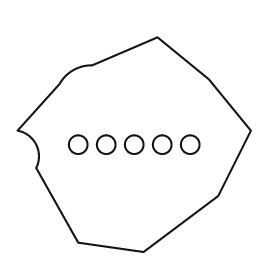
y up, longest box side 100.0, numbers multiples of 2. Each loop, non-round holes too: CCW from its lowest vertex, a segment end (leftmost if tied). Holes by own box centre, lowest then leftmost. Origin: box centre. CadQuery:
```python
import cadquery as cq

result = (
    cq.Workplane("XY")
    .moveTo(4.0, -46.0)
    .lineTo(36.0, -22.0)
    .lineTo(50.0, 6.0)
    .lineTo(32.0, 28.0)
    .lineTo(10.0, 46.0)
    .lineTo(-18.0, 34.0)
    .threePointArc((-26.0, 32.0), (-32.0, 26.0))
    .lineTo(-50.0, 6.0)
    .threePointArc((-42.0, 0.0), (-42.0, -10.0))
    .lineTo(-24.0, -42.0)
    .close()
    .moveTo(-24.0, 0.0)
    .circle(4.0)
    .moveTo(-12.0, 0.0)
    .circle(4.0)
    .moveTo(0.0, 0.0)
    .circle(4.0)
    .moveTo(12.0, 0.0)
    .circle(4.0)
    .moveTo(24.0, 0.0)
    .circle(4.0)
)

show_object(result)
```